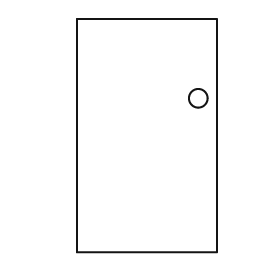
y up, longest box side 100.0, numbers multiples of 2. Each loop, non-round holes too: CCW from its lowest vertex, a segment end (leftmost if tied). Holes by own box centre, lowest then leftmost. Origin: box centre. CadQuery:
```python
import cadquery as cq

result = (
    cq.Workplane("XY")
    .moveTo(-30.0, -50.0)
    .lineTo(30.0, -50.0)
    .lineTo(30.0, 50.0)
    .lineTo(-30.0, 50.0)
    .close()
    .moveTo(22.0, 16.0)
    .circle(4.0)
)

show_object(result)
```